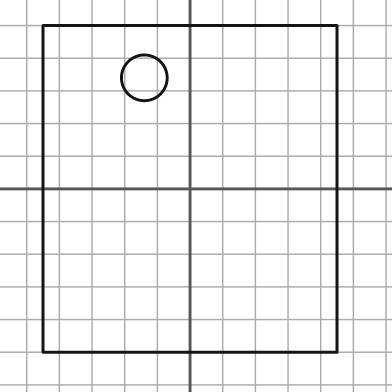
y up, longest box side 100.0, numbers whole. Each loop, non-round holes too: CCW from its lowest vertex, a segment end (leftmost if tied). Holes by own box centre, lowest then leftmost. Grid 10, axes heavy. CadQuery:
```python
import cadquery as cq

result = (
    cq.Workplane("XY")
    .moveTo(-45.0, -50.0)
    .lineTo(45.0, -50.0)
    .lineTo(45.0, 50.0)
    .lineTo(-45.0, 50.0)
    .close()
    .moveTo(-14.0, 34.0)
    .circle(7.0)
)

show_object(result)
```